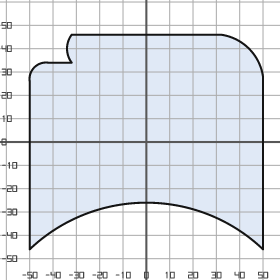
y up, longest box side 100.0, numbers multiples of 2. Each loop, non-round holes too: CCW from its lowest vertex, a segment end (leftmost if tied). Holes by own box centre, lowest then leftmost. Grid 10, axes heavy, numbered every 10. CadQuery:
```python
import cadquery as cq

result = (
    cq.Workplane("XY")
    .moveTo(-50.0, -46.0)
    .threePointArc((0.0, -26.0), (50.0, -46.0))
    .lineTo(50.0, 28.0)
    .threePointArc((44.0, 40.0), (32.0, 46.0))
    .lineTo(-32.0, 46.0)
    .threePointArc((-34.0, 40.0), (-32.0, 34.0))
    .lineTo(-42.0, 34.0)
    .threePointArc((-48.0, 32.0), (-50.0, 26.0))
    .close()
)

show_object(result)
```